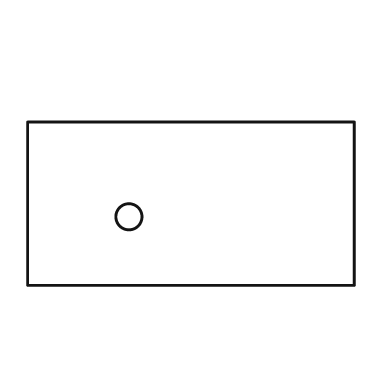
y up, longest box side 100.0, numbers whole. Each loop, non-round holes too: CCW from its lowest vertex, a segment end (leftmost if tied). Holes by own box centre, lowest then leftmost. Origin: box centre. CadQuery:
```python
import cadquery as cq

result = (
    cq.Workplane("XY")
    .moveTo(-50.0, -25.0)
    .lineTo(50.0, -25.0)
    .lineTo(50.0, 25.0)
    .lineTo(-50.0, 25.0)
    .close()
    .moveTo(-19.0, -4.0)
    .circle(4.0)
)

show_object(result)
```